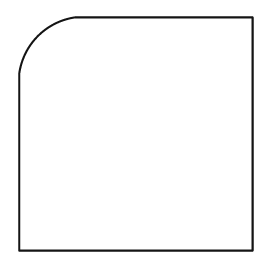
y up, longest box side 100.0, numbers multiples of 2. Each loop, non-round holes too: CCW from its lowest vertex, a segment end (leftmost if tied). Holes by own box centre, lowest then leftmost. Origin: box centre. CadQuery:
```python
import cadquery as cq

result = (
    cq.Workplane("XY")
    .moveTo(-50.0, -50.0)
    .lineTo(50.0, -50.0)
    .lineTo(50.0, 50.0)
    .lineTo(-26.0, 50.0)
    .threePointArc((-42.0, 42.0), (-50.0, 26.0))
    .close()
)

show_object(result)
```